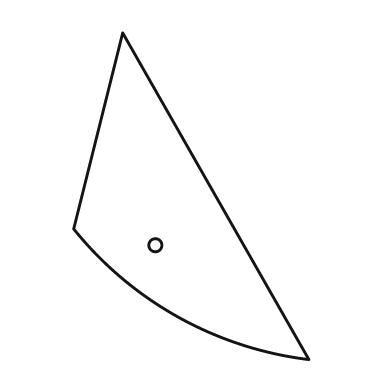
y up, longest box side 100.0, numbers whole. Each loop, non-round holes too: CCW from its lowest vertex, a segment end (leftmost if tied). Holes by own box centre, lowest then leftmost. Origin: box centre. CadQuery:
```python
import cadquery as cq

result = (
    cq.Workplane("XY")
    .moveTo(36.0, -50.0)
    .lineTo(-21.0, 50.0)
    .lineTo(-36.0, -10.0)
    .threePointArc((-4.0, -37.0), (36.0, -50.0))
    .close()
    .moveTo(-11.0, -15.0)
    .circle(2.0)
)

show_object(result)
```